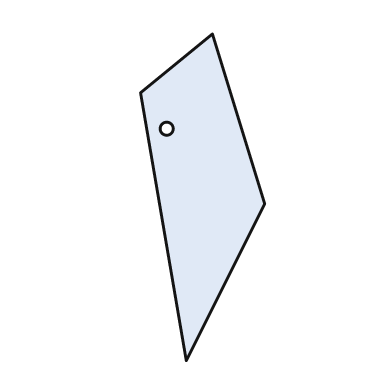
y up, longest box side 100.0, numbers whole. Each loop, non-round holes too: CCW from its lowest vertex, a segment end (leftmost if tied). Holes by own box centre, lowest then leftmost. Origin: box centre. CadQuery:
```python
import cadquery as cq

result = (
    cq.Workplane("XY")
    .moveTo(-5.0, -50.0)
    .lineTo(19.0, -2.0)
    .lineTo(3.0, 50.0)
    .lineTo(-19.0, 32.0)
    .close()
    .moveTo(-11.0, 21.0)
    .circle(2.0)
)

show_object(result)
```